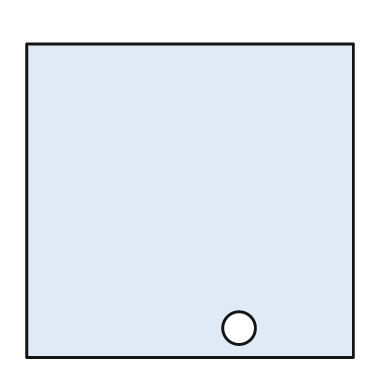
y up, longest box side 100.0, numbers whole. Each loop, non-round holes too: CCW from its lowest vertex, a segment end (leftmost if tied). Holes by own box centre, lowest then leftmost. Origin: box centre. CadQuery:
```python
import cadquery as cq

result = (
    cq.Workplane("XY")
    .moveTo(-50.0, -48.0)
    .lineTo(50.0, -48.0)
    .lineTo(50.0, 48.0)
    .lineTo(-50.0, 48.0)
    .close()
    .moveTo(15.0, -39.0)
    .circle(5.0)
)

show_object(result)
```